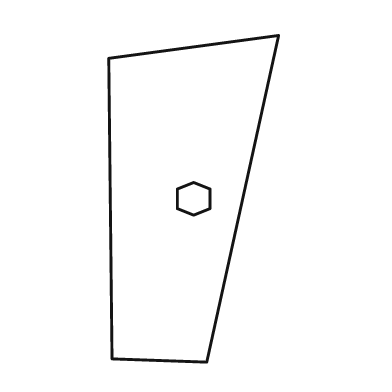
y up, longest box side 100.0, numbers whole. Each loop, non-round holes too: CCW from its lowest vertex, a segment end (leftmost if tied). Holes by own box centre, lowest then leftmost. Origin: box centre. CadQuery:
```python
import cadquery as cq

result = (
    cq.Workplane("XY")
    .moveTo(4.0, -50.0)
    .lineTo(26.0, 50.0)
    .lineTo(-26.0, 43.0)
    .lineTo(-25.0, -49.0)
    .close()
    .moveTo(0.0, -5.0)
    .lineTo(5.0, -3.0)
    .lineTo(5.0, 3.0)
    .lineTo(0.0, 5.0)
    .lineTo(-5.0, 3.0)
    .lineTo(-5.0, -3.0)
    .close()
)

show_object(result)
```